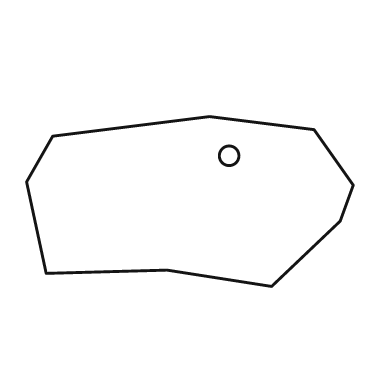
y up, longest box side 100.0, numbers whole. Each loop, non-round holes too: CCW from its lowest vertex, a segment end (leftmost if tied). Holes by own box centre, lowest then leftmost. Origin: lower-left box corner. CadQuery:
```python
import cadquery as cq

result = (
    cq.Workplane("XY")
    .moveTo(75.0, 0.0)
    .lineTo(96.0, 20.0)
    .lineTo(100.0, 31.0)
    .lineTo(88.0, 48.0)
    .lineTo(56.0, 52.0)
    .lineTo(8.0, 46.0)
    .lineTo(0.0, 32.0)
    .lineTo(6.0, 4.0)
    .lineTo(43.0, 5.0)
    .close()
    .moveTo(62.0, 40.0)
    .circle(3.0)
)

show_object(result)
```